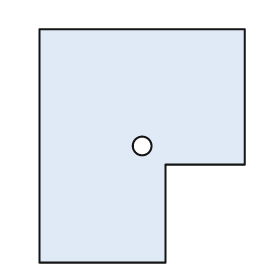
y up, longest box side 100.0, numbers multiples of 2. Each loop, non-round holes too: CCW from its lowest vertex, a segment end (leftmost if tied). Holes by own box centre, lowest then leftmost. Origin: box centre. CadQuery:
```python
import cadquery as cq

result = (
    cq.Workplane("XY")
    .moveTo(-44.0, -50.0)
    .lineTo(10.0, -50.0)
    .lineTo(10.0, -8.0)
    .lineTo(44.0, -8.0)
    .lineTo(44.0, 50.0)
    .lineTo(-44.0, 50.0)
    .close()
    .moveTo(0.0, 0.0)
    .circle(4.0)
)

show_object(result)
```